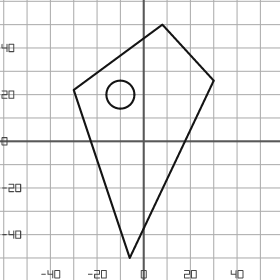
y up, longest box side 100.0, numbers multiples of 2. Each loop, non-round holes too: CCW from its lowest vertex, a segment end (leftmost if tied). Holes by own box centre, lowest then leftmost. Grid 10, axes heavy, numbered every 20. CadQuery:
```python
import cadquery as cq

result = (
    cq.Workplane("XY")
    .moveTo(-6.0, -50.0)
    .lineTo(30.0, 26.0)
    .lineTo(8.0, 50.0)
    .lineTo(-30.0, 22.0)
    .close()
    .moveTo(-10.0, 20.0)
    .circle(6.0)
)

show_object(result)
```